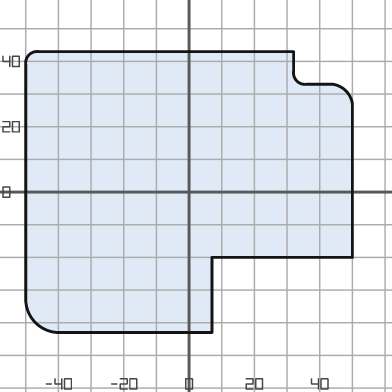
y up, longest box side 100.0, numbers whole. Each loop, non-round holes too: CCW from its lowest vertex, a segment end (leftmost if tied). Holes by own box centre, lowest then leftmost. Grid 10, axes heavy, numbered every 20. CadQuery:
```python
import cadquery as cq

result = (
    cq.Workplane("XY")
    .moveTo(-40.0, -43.0)
    .lineTo(7.0, -43.0)
    .lineTo(7.0, -20.0)
    .lineTo(50.0, -20.0)
    .lineTo(50.0, 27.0)
    .threePointArc((48.0, 31.0), (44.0, 33.0))
    .lineTo(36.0, 33.0)
    .threePointArc((33.0, 34.0), (32.0, 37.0))
    .lineTo(32.0, 43.0)
    .lineTo(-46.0, 43.0)
    .threePointArc((-49.0, 42.0), (-50.0, 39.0))
    .lineTo(-50.0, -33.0)
    .threePointArc((-47.0, -40.0), (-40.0, -43.0))
    .close()
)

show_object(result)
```